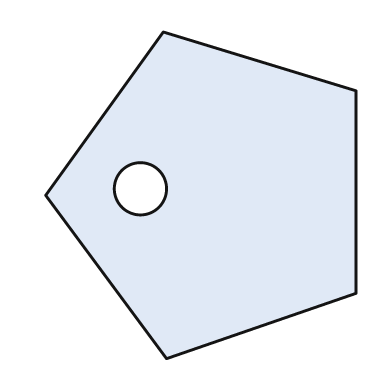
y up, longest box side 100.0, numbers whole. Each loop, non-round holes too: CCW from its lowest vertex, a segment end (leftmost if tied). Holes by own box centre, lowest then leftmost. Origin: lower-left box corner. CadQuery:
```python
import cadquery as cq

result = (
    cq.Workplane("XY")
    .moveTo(37.0, 0.0)
    .lineTo(95.0, 20.0)
    .lineTo(95.0, 82.0)
    .lineTo(36.0, 100.0)
    .lineTo(0.0, 50.0)
    .close()
    .moveTo(29.0, 52.0)
    .circle(8.0)
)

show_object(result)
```